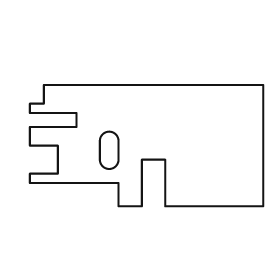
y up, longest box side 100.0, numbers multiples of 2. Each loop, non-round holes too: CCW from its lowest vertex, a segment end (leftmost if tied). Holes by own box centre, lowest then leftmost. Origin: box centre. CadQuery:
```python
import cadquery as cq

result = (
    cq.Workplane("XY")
    .moveTo(-12.0, -26.0)
    .lineTo(-2.0, -26.0)
    .lineTo(-2.0, -6.0)
    .lineTo(8.0, -6.0)
    .lineTo(8.0, -26.0)
    .lineTo(50.0, -26.0)
    .lineTo(50.0, 26.0)
    .lineTo(-44.0, 26.0)
    .lineTo(-44.0, 18.0)
    .lineTo(-50.0, 18.0)
    .lineTo(-50.0, 14.0)
    .lineTo(-30.0, 14.0)
    .lineTo(-30.0, 8.0)
    .lineTo(-50.0, 8.0)
    .lineTo(-50.0, 0.0)
    .lineTo(-38.0, 0.0)
    .lineTo(-38.0, -12.0)
    .lineTo(-50.0, -12.0)
    .lineTo(-50.0, -16.0)
    .lineTo(-12.0, -16.0)
    .close()
    .moveTo(-20.0, -6.0)
    .threePointArc((-16.0, -10.0), (-12.0, -6.0))
    .lineTo(-12.0, 2.0)
    .threePointArc((-16.0, 6.0), (-20.0, 2.0))
    .close()
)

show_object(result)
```